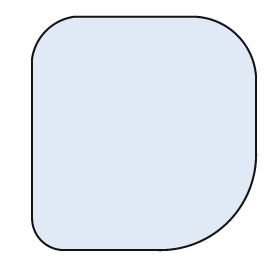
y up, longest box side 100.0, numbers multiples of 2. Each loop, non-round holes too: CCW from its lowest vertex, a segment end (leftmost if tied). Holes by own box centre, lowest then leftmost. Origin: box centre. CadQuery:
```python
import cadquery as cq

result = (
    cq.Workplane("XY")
    .moveTo(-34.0, -50.0)
    .lineTo(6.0, -50.0)
    .threePointArc((36.0, -38.0), (48.0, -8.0))
    .lineTo(48.0, 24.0)
    .threePointArc((40.0, 42.0), (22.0, 50.0))
    .lineTo(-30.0, 50.0)
    .threePointArc((-42.0, 44.0), (-48.0, 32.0))
    .lineTo(-48.0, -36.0)
    .threePointArc((-44.0, -46.0), (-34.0, -50.0))
    .close()
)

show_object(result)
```